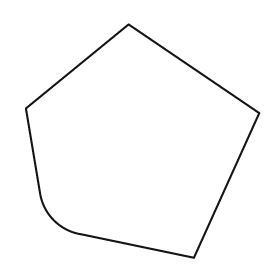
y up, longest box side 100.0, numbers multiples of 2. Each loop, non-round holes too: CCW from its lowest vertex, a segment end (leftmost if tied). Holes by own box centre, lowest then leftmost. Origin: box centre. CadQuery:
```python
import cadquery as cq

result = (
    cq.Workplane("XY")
    .moveTo(22.0, -50.0)
    .lineTo(50.0, 12.0)
    .lineTo(-6.0, 50.0)
    .lineTo(-50.0, 14.0)
    .lineTo(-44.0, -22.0)
    .threePointArc((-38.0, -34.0), (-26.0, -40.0))
    .close()
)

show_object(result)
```